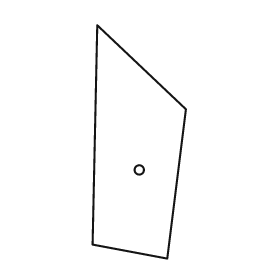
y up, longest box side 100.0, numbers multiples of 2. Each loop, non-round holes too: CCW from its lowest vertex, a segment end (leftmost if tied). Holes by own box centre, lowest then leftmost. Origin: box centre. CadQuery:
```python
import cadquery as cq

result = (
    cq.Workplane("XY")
    .moveTo(12.0, -50.0)
    .lineTo(20.0, 14.0)
    .lineTo(-18.0, 50.0)
    .lineTo(-20.0, -44.0)
    .close()
    .moveTo(0.0, -12.0)
    .circle(2.0)
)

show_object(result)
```